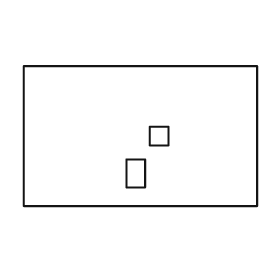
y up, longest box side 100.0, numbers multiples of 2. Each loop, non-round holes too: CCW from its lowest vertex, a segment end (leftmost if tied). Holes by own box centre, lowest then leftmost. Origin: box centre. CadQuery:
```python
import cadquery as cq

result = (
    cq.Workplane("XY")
    .moveTo(-50.0, -30.0)
    .lineTo(50.0, -30.0)
    .lineTo(50.0, 30.0)
    .lineTo(-50.0, 30.0)
    .close()
    .moveTo(-6.0, -22.0)
    .lineTo(2.0, -22.0)
    .lineTo(2.0, -10.0)
    .lineTo(-6.0, -10.0)
    .close()
    .moveTo(4.0, -4.0)
    .lineTo(12.0, -4.0)
    .lineTo(12.0, 4.0)
    .lineTo(4.0, 4.0)
    .close()
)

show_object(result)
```